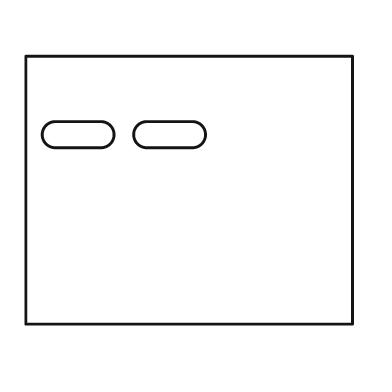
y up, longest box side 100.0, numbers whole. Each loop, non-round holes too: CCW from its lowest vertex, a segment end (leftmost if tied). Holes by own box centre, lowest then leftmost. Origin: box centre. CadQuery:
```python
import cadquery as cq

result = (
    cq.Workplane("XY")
    .moveTo(-50.0, -41.0)
    .lineTo(50.0, -41.0)
    .lineTo(50.0, 41.0)
    .lineTo(-50.0, 41.0)
    .close()
    .moveTo(-41.0, 13.0)
    .lineTo(-27.0, 13.0)
    .threePointArc((-23.0, 17.0), (-27.0, 21.0))
    .lineTo(-41.0, 21.0)
    .threePointArc((-45.0, 17.0), (-41.0, 13.0))
    .close()
    .moveTo(-13.0, 13.0)
    .lineTo(1.0, 13.0)
    .threePointArc((5.0, 17.0), (1.0, 21.0))
    .lineTo(-13.0, 21.0)
    .threePointArc((-17.0, 17.0), (-13.0, 13.0))
    .close()
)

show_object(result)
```